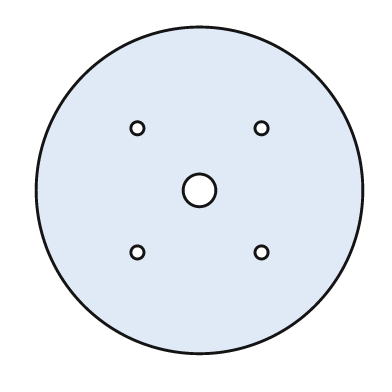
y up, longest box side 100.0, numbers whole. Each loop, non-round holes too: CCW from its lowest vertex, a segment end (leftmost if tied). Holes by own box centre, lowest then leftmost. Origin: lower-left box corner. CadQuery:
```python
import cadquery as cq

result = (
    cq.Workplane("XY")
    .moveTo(50.0, 50.0)
    .circle(50.0)
    .moveTo(31.0, 31.0)
    .circle(2.0)
    .moveTo(69.0, 31.0)
    .circle(2.0)
    .moveTo(50.0, 50.0)
    .circle(5.0)
    .moveTo(31.0, 69.0)
    .circle(2.0)
    .moveTo(69.0, 69.0)
    .circle(2.0)
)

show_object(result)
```